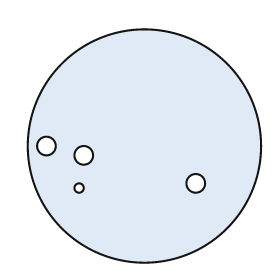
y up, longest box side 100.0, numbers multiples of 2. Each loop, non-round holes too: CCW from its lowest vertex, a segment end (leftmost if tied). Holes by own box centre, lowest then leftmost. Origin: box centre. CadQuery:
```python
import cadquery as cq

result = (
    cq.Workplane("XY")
    .moveTo(0.0, 0.0)
    .circle(50.0)
    .moveTo(-28.0, -18.0)
    .circle(2.0)
    .moveTo(22.0, -16.0)
    .circle(4.0)
    .moveTo(-26.0, -4.0)
    .circle(4.0)
    .moveTo(-42.0, 0.0)
    .circle(4.0)
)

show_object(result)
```